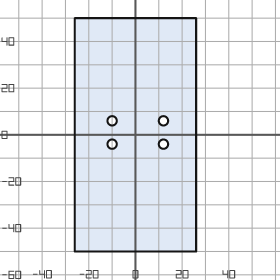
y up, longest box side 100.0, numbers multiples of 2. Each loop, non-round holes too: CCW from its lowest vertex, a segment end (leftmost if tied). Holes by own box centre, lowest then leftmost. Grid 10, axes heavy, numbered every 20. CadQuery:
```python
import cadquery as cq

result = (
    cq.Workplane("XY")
    .moveTo(-26.0, -50.0)
    .lineTo(26.0, -50.0)
    .lineTo(26.0, 50.0)
    .lineTo(-26.0, 50.0)
    .close()
    .moveTo(-10.0, -4.0)
    .circle(2.0)
    .moveTo(12.0, -4.0)
    .circle(2.0)
    .moveTo(-10.0, 6.0)
    .circle(2.0)
    .moveTo(12.0, 6.0)
    .circle(2.0)
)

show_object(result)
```